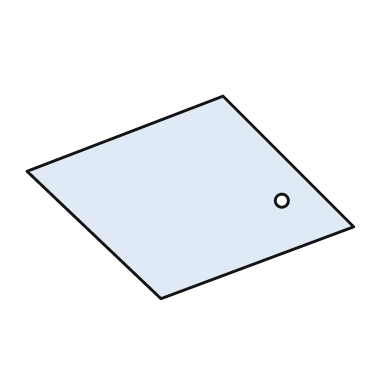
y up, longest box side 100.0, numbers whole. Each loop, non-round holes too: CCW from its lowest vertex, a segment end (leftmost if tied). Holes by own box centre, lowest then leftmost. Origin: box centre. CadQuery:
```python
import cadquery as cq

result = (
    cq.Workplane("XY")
    .moveTo(-9.0, -31.0)
    .lineTo(50.0, -9.0)
    .lineTo(10.0, 31.0)
    .lineTo(-50.0, 8.0)
    .close()
    .moveTo(28.0, -1.0)
    .circle(2.0)
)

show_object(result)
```